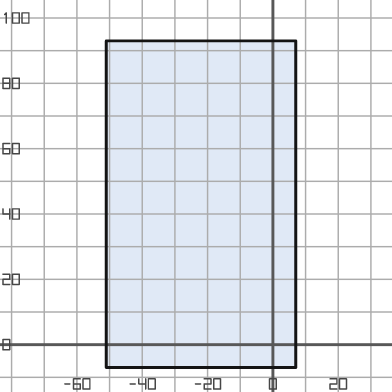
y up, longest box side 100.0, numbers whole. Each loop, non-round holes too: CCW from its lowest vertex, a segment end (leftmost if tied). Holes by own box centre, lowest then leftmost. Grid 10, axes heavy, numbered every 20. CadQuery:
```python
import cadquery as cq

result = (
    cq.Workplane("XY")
    .moveTo(-51.0, -7.0)
    .lineTo(7.0, -7.0)
    .lineTo(7.0, 93.0)
    .lineTo(-51.0, 93.0)
    .close()
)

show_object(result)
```